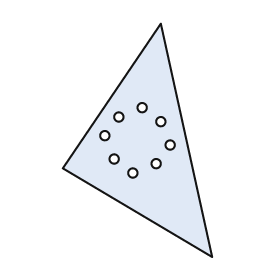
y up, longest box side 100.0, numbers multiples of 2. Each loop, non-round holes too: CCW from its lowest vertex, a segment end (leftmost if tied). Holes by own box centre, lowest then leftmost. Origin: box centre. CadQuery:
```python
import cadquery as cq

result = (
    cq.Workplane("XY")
    .moveTo(32.0, -50.0)
    .lineTo(10.0, 50.0)
    .lineTo(-32.0, -12.0)
    .close()
    .moveTo(-2.0, -14.0)
    .circle(2.0)
    .moveTo(8.0, -10.0)
    .circle(2.0)
    .moveTo(-10.0, -8.0)
    .circle(2.0)
    .moveTo(14.0, -2.0)
    .circle(2.0)
    .moveTo(-14.0, 2.0)
    .circle(2.0)
    .moveTo(10.0, 8.0)
    .circle(2.0)
    .moveTo(-8.0, 10.0)
    .circle(2.0)
    .moveTo(2.0, 14.0)
    .circle(2.0)
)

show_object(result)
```